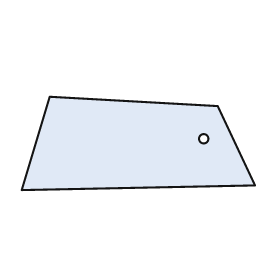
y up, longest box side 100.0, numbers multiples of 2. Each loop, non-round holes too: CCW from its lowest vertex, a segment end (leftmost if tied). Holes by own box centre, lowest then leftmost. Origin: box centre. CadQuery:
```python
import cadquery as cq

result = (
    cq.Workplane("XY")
    .moveTo(-50.0, -20.0)
    .lineTo(50.0, -18.0)
    .lineTo(34.0, 16.0)
    .lineTo(-38.0, 20.0)
    .close()
    .moveTo(28.0, 2.0)
    .circle(2.0)
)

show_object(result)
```